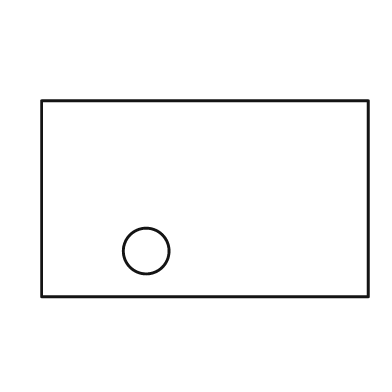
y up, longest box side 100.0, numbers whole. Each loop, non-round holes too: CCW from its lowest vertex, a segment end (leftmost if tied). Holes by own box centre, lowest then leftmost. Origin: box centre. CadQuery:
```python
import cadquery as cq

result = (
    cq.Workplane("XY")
    .moveTo(-50.0, -30.0)
    .lineTo(50.0, -30.0)
    .lineTo(50.0, 30.0)
    .lineTo(-50.0, 30.0)
    .close()
    .moveTo(-18.0, -16.0)
    .circle(7.0)
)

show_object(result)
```